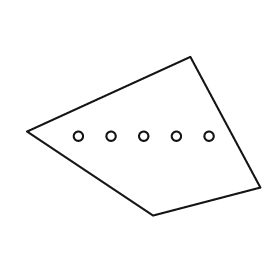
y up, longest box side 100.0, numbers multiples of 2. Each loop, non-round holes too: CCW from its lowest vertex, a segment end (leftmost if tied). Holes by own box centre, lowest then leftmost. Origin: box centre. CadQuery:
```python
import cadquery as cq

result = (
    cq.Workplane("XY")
    .moveTo(4.0, -34.0)
    .lineTo(50.0, -22.0)
    .lineTo(20.0, 34.0)
    .lineTo(-50.0, 2.0)
    .close()
    .moveTo(-28.0, 0.0)
    .circle(2.0)
    .moveTo(-14.0, 0.0)
    .circle(2.0)
    .moveTo(0.0, 0.0)
    .circle(2.0)
    .moveTo(14.0, 0.0)
    .circle(2.0)
    .moveTo(28.0, 0.0)
    .circle(2.0)
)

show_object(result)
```